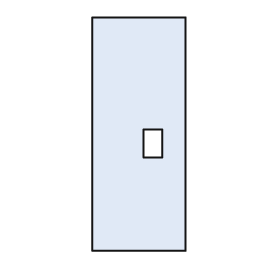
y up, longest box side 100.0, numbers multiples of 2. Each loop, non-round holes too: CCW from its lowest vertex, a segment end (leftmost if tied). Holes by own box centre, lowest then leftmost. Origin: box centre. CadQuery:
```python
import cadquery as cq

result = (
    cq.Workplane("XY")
    .moveTo(-20.0, -50.0)
    .lineTo(20.0, -50.0)
    .lineTo(20.0, 50.0)
    .lineTo(-20.0, 50.0)
    .close()
    .moveTo(2.0, -10.0)
    .lineTo(10.0, -10.0)
    .lineTo(10.0, 2.0)
    .lineTo(2.0, 2.0)
    .close()
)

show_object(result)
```